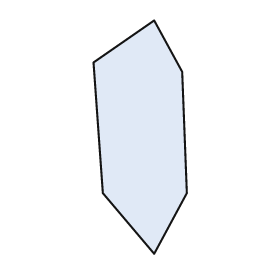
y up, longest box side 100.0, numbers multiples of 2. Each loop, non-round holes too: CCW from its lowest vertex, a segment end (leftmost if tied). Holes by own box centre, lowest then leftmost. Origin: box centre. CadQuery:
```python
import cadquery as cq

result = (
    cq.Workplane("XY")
    .moveTo(6.0, -50.0)
    .lineTo(20.0, -24.0)
    .lineTo(18.0, 28.0)
    .lineTo(6.0, 50.0)
    .lineTo(-20.0, 32.0)
    .lineTo(-16.0, -24.0)
    .close()
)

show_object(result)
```